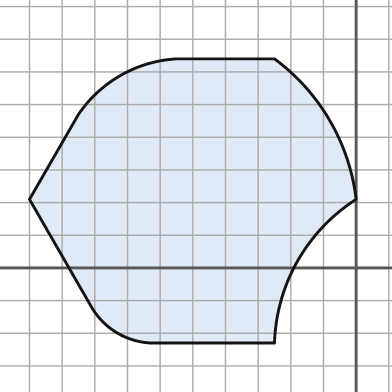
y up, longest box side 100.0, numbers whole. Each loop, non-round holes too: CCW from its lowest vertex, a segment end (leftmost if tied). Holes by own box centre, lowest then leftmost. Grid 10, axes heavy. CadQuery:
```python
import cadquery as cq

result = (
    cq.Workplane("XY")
    .moveTo(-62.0, -23.0)
    .lineTo(-25.0, -23.0)
    .threePointArc((-18.0, 2.0), (0.0, 21.0))
    .threePointArc((-8.0, 45.0), (-25.0, 64.0))
    .lineTo(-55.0, 64.0)
    .threePointArc((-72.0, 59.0), (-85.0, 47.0))
    .lineTo(-100.0, 21.0)
    .lineTo(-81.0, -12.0)
    .threePointArc((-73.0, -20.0), (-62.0, -23.0))
    .close()
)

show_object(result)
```